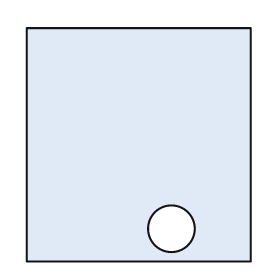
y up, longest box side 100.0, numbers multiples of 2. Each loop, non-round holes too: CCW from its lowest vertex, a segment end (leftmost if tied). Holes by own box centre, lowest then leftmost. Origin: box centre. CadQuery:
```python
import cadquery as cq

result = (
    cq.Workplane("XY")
    .moveTo(-48.0, -50.0)
    .lineTo(48.0, -50.0)
    .lineTo(48.0, 50.0)
    .lineTo(-48.0, 50.0)
    .close()
    .moveTo(14.0, -36.0)
    .circle(10.0)
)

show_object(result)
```